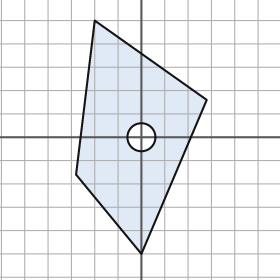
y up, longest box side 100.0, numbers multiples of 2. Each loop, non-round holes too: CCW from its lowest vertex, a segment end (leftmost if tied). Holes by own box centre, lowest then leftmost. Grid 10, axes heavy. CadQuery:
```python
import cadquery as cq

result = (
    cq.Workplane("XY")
    .moveTo(0.0, -50.0)
    .lineTo(28.0, 16.0)
    .lineTo(-20.0, 50.0)
    .lineTo(-28.0, -16.0)
    .close()
    .moveTo(0.0, 0.0)
    .circle(6.0)
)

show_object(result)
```